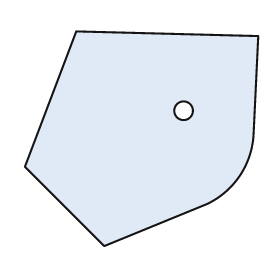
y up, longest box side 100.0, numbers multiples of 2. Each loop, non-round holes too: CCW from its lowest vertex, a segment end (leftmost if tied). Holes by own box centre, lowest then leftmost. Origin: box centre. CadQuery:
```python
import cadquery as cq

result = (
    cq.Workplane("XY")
    .moveTo(-16.0, -46.0)
    .lineTo(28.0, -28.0)
    .threePointArc((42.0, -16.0), (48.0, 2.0))
    .lineTo(50.0, 44.0)
    .lineTo(-28.0, 46.0)
    .lineTo(-50.0, -12.0)
    .close()
    .moveTo(18.0, 12.0)
    .circle(4.0)
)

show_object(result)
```